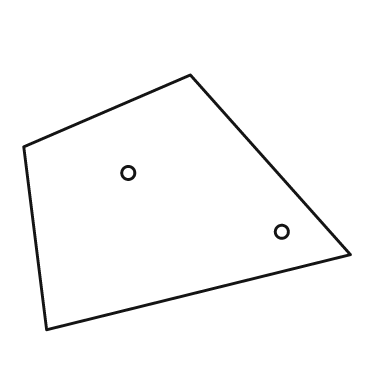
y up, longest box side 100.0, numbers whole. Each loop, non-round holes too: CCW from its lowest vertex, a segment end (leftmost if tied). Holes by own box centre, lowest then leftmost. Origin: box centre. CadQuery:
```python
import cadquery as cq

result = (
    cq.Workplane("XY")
    .moveTo(-43.0, -39.0)
    .lineTo(50.0, -16.0)
    .lineTo(1.0, 39.0)
    .lineTo(-50.0, 17.0)
    .close()
    .moveTo(29.0, -9.0)
    .circle(2.0)
    .moveTo(-18.0, 9.0)
    .circle(2.0)
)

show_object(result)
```